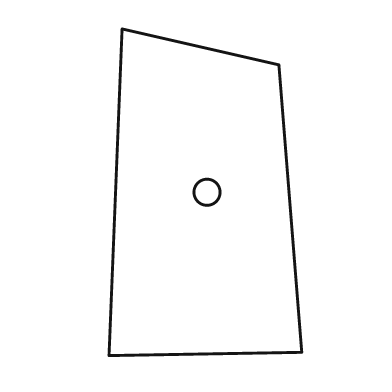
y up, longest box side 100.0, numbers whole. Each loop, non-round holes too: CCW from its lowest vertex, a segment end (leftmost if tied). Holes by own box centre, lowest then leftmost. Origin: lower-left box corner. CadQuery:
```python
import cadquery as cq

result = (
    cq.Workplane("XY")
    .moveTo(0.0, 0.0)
    .lineTo(59.0, 1.0)
    .lineTo(52.0, 89.0)
    .lineTo(4.0, 100.0)
    .close()
    .moveTo(30.0, 50.0)
    .circle(4.0)
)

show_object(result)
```